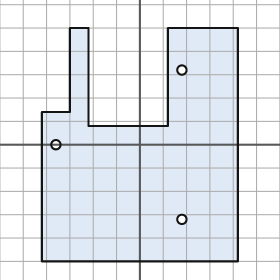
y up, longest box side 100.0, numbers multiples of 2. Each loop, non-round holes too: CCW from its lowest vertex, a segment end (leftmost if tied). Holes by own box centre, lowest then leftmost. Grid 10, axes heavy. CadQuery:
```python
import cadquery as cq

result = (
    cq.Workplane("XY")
    .moveTo(-42.0, -50.0)
    .lineTo(42.0, -50.0)
    .lineTo(42.0, 50.0)
    .lineTo(12.0, 50.0)
    .lineTo(12.0, 8.0)
    .lineTo(-22.0, 8.0)
    .lineTo(-22.0, 50.0)
    .lineTo(-30.0, 50.0)
    .lineTo(-30.0, 14.0)
    .lineTo(-42.0, 14.0)
    .close()
    .moveTo(18.0, -32.0)
    .circle(2.0)
    .moveTo(-36.0, 0.0)
    .circle(2.0)
    .moveTo(18.0, 32.0)
    .circle(2.0)
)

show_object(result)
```